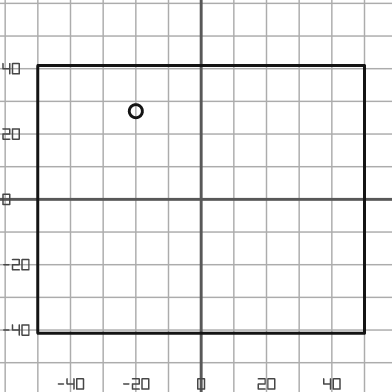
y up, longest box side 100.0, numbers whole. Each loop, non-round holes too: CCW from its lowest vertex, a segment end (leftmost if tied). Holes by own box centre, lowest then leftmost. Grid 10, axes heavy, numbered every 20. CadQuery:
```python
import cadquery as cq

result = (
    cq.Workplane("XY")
    .moveTo(-50.0, -41.0)
    .lineTo(50.0, -41.0)
    .lineTo(50.0, 41.0)
    .lineTo(-50.0, 41.0)
    .close()
    .moveTo(-20.0, 27.0)
    .circle(2.0)
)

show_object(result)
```